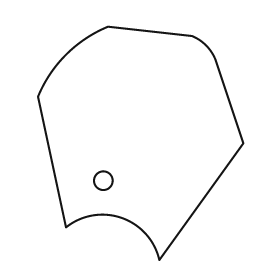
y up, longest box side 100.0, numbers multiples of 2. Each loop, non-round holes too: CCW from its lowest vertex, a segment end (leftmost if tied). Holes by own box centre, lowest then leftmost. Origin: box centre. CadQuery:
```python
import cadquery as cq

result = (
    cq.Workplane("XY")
    .moveTo(8.0, -50.0)
    .lineTo(44.0, 0.0)
    .lineTo(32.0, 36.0)
    .threePointArc((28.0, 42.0), (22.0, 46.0))
    .lineTo(-14.0, 50.0)
    .threePointArc((-32.0, 38.0), (-44.0, 20.0))
    .lineTo(-32.0, -36.0)
    .threePointArc((-8.0, -32.0), (8.0, -50.0))
    .close()
    .moveTo(-16.0, -16.0)
    .circle(4.0)
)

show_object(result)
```